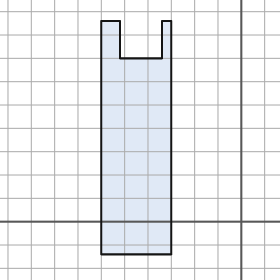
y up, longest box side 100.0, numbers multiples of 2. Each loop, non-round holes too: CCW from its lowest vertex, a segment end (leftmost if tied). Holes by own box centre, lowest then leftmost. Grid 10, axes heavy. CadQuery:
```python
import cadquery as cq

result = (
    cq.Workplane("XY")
    .moveTo(-60.0, -14.0)
    .lineTo(-30.0, -14.0)
    .lineTo(-30.0, 86.0)
    .lineTo(-34.0, 86.0)
    .lineTo(-34.0, 70.0)
    .lineTo(-52.0, 70.0)
    .lineTo(-52.0, 86.0)
    .lineTo(-60.0, 86.0)
    .close()
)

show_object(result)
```